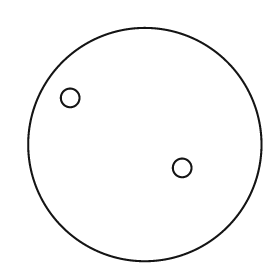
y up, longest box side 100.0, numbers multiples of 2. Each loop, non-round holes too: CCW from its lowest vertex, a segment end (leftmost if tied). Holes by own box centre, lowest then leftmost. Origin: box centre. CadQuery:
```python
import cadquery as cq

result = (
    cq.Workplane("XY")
    .moveTo(0.0, 0.0)
    .circle(50.0)
    .moveTo(16.0, -10.0)
    .circle(4.0)
    .moveTo(-32.0, 20.0)
    .circle(4.0)
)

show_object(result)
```